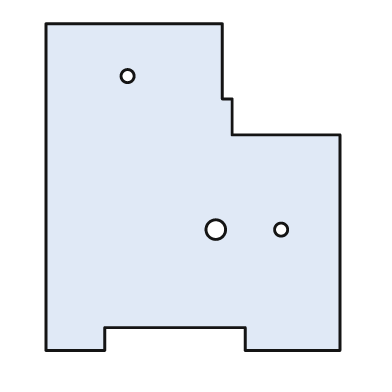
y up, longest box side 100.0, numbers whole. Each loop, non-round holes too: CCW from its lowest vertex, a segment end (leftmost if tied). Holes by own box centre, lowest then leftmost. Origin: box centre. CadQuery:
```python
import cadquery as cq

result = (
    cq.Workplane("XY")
    .moveTo(-45.0, -50.0)
    .lineTo(-27.0, -50.0)
    .lineTo(-27.0, -43.0)
    .lineTo(16.0, -43.0)
    .lineTo(16.0, -50.0)
    .lineTo(45.0, -50.0)
    .lineTo(45.0, 16.0)
    .lineTo(12.0, 16.0)
    .lineTo(12.0, 27.0)
    .lineTo(9.0, 27.0)
    .lineTo(9.0, 50.0)
    .lineTo(-45.0, 50.0)
    .close()
    .moveTo(7.0, -13.0)
    .circle(3.0)
    .moveTo(27.0, -13.0)
    .circle(2.0)
    .moveTo(-20.0, 34.0)
    .circle(2.0)
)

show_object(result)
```